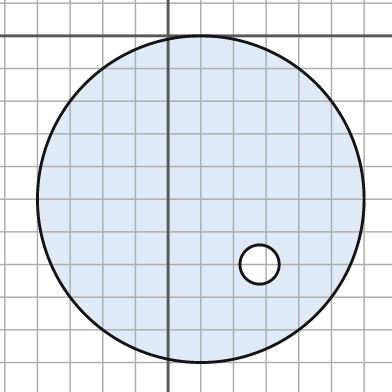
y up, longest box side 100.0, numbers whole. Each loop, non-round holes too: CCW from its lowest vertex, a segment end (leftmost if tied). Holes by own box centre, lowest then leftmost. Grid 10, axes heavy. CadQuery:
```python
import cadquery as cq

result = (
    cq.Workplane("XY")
    .moveTo(10.0, -50.0)
    .circle(50.0)
    .moveTo(28.0, -70.0)
    .circle(6.0)
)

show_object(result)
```